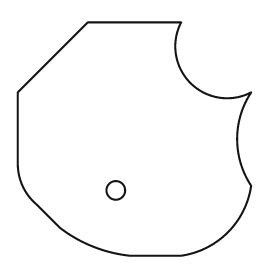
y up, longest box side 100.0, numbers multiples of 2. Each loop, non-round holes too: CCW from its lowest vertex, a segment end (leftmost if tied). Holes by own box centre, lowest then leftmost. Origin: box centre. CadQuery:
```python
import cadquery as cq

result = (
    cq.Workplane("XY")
    .moveTo(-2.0, -50.0)
    .lineTo(20.0, -50.0)
    .threePointArc((40.0, -40.0), (50.0, -20.0))
    .threePointArc((44.0, 0.0), (50.0, 20.0))
    .threePointArc((24.0, 24.0), (20.0, 50.0))
    .lineTo(-20.0, 50.0)
    .lineTo(-50.0, 20.0)
    .lineTo(-50.0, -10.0)
    .threePointArc((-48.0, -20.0), (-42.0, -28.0))
    .lineTo(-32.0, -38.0)
    .threePointArc((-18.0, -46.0), (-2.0, -50.0))
    .close()
    .moveTo(-8.0, -22.0)
    .circle(4.0)
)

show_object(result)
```